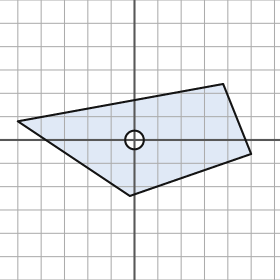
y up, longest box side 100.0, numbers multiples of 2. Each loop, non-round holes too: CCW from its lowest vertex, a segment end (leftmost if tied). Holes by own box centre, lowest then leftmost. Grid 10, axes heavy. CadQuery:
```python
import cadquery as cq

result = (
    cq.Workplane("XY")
    .moveTo(-2.0, -24.0)
    .lineTo(50.0, -6.0)
    .lineTo(38.0, 24.0)
    .lineTo(-50.0, 8.0)
    .close()
    .moveTo(0.0, 0.0)
    .circle(4.0)
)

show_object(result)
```